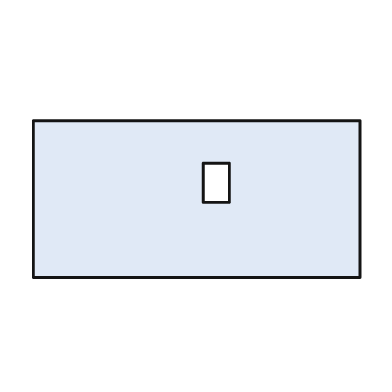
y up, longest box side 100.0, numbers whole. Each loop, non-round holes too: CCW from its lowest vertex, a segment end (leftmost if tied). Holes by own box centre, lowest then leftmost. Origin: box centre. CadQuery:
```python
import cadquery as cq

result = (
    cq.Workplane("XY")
    .moveTo(-50.0, -24.0)
    .lineTo(50.0, -24.0)
    .lineTo(50.0, 24.0)
    .lineTo(-50.0, 24.0)
    .close()
    .moveTo(2.0, -1.0)
    .lineTo(10.0, -1.0)
    .lineTo(10.0, 11.0)
    .lineTo(2.0, 11.0)
    .close()
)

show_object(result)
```